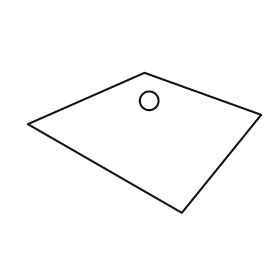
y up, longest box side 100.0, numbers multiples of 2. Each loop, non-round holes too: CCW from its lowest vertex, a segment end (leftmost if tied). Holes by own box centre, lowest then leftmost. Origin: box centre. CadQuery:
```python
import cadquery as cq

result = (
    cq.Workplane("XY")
    .moveTo(16.0, -30.0)
    .lineTo(50.0, 12.0)
    .lineTo(0.0, 30.0)
    .lineTo(-50.0, 8.0)
    .close()
    .moveTo(2.0, 18.0)
    .circle(4.0)
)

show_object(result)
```